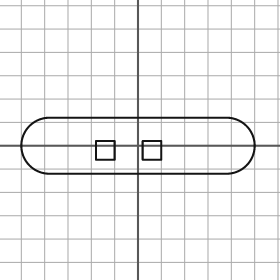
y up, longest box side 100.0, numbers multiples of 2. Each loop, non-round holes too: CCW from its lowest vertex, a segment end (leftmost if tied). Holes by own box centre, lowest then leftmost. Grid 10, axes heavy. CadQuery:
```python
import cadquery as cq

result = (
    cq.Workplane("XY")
    .moveTo(-38.0, -12.0)
    .lineTo(38.0, -12.0)
    .threePointArc((50.0, 0.0), (38.0, 12.0))
    .lineTo(-38.0, 12.0)
    .threePointArc((-50.0, 0.0), (-38.0, -12.0))
    .close()
    .moveTo(-18.0, -6.0)
    .lineTo(-10.0, -6.0)
    .lineTo(-10.0, 2.0)
    .lineTo(-18.0, 2.0)
    .close()
    .moveTo(2.0, -6.0)
    .lineTo(10.0, -6.0)
    .lineTo(10.0, 2.0)
    .lineTo(2.0, 2.0)
    .close()
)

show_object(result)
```